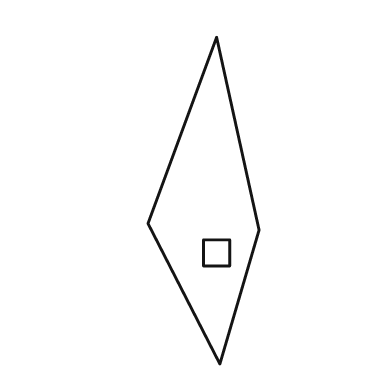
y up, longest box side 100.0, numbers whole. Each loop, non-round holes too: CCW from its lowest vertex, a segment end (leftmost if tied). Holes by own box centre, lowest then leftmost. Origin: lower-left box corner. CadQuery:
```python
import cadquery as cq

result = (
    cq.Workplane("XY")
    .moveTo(22.0, 0.0)
    .lineTo(34.0, 41.0)
    .lineTo(21.0, 100.0)
    .lineTo(0.0, 43.0)
    .close()
    .moveTo(17.0, 30.0)
    .lineTo(25.0, 30.0)
    .lineTo(25.0, 38.0)
    .lineTo(17.0, 38.0)
    .close()
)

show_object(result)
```